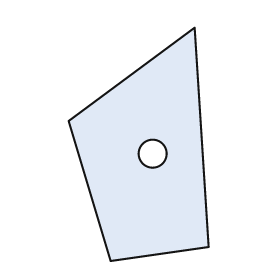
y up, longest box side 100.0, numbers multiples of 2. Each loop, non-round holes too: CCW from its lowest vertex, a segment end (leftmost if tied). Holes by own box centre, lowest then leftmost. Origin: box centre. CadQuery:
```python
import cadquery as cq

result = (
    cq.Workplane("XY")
    .moveTo(-12.0, -50.0)
    .lineTo(30.0, -44.0)
    .lineTo(24.0, 50.0)
    .lineTo(-30.0, 10.0)
    .close()
    .moveTo(6.0, -4.0)
    .circle(6.0)
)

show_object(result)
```